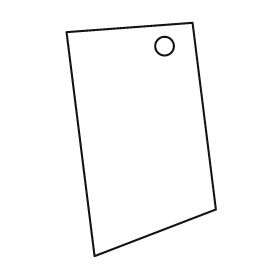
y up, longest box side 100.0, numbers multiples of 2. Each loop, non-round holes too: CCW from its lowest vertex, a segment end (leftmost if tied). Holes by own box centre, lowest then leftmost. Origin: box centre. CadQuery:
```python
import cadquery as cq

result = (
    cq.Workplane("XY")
    .moveTo(-20.0, -50.0)
    .lineTo(32.0, -30.0)
    .lineTo(22.0, 50.0)
    .lineTo(-32.0, 46.0)
    .close()
    .moveTo(10.0, 40.0)
    .circle(4.0)
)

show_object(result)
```